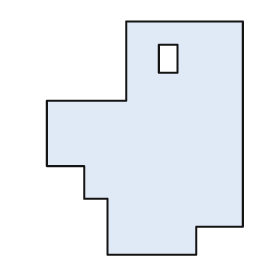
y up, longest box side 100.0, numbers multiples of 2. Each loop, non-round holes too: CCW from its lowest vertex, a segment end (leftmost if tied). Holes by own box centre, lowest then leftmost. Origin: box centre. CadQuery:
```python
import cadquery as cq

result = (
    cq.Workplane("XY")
    .moveTo(-16.0, -50.0)
    .lineTo(22.0, -50.0)
    .lineTo(22.0, -38.0)
    .lineTo(42.0, -38.0)
    .lineTo(42.0, 50.0)
    .lineTo(-8.0, 50.0)
    .lineTo(-8.0, 16.0)
    .lineTo(-42.0, 16.0)
    .lineTo(-42.0, -12.0)
    .lineTo(-26.0, -12.0)
    .lineTo(-26.0, -26.0)
    .lineTo(-16.0, -26.0)
    .close()
    .moveTo(6.0, 28.0)
    .lineTo(14.0, 28.0)
    .lineTo(14.0, 40.0)
    .lineTo(6.0, 40.0)
    .close()
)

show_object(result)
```